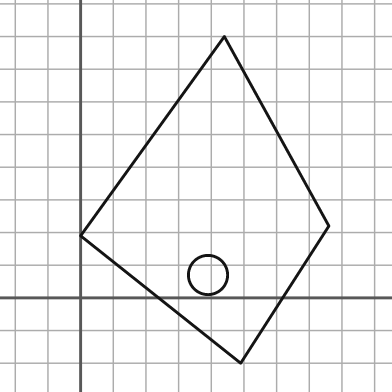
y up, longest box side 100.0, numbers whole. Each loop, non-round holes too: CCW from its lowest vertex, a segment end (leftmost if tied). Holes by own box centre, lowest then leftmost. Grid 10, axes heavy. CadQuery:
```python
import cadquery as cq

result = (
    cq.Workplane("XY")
    .moveTo(49.0, -20.0)
    .lineTo(76.0, 22.0)
    .lineTo(44.0, 80.0)
    .lineTo(0.0, 19.0)
    .close()
    .moveTo(39.0, 7.0)
    .circle(6.0)
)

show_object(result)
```